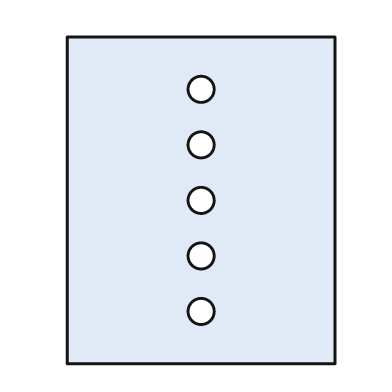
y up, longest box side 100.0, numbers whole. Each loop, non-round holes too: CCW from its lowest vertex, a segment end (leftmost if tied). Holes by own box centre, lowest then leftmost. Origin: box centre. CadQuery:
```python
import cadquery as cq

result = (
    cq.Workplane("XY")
    .moveTo(-41.0, -50.0)
    .lineTo(41.0, -50.0)
    .lineTo(41.0, 50.0)
    .lineTo(-41.0, 50.0)
    .close()
    .moveTo(0.0, -34.0)
    .circle(4.0)
    .moveTo(0.0, -17.0)
    .circle(4.0)
    .moveTo(0.0, 0.0)
    .circle(4.0)
    .moveTo(0.0, 17.0)
    .circle(4.0)
    .moveTo(0.0, 34.0)
    .circle(4.0)
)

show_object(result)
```